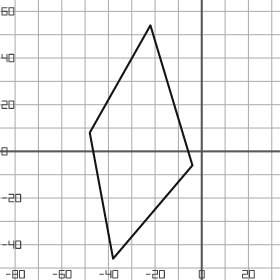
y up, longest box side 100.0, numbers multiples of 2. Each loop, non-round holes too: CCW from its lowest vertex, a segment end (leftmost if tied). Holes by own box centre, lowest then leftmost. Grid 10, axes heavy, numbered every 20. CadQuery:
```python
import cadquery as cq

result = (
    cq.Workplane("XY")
    .moveTo(-38.0, -46.0)
    .lineTo(-4.0, -6.0)
    .lineTo(-22.0, 54.0)
    .lineTo(-48.0, 8.0)
    .close()
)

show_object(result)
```